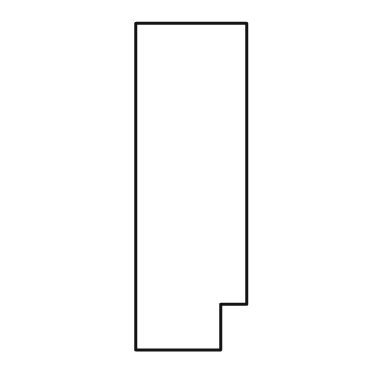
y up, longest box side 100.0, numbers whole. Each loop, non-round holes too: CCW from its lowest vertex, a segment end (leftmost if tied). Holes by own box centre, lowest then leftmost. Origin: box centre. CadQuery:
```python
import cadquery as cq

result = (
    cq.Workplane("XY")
    .moveTo(-17.0, -50.0)
    .lineTo(9.0, -50.0)
    .lineTo(9.0, -36.0)
    .lineTo(17.0, -36.0)
    .lineTo(17.0, 50.0)
    .lineTo(-17.0, 50.0)
    .close()
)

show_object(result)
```